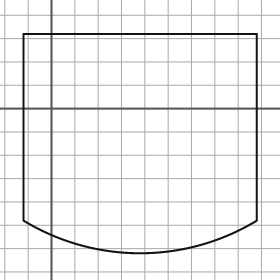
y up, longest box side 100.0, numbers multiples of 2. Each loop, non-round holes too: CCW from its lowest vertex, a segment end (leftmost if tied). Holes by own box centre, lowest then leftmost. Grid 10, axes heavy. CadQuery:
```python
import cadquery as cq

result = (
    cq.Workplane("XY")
    .moveTo(-12.0, -48.0)
    .threePointArc((38.0, -62.0), (88.0, -48.0))
    .lineTo(88.0, 32.0)
    .lineTo(-12.0, 32.0)
    .close()
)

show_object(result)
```